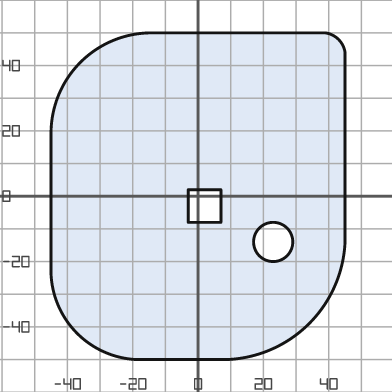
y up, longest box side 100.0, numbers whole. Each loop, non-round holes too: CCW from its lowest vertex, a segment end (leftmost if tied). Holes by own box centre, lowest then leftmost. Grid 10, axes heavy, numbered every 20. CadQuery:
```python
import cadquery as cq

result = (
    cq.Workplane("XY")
    .moveTo(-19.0, -50.0)
    .lineTo(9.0, -50.0)
    .threePointArc((34.0, -39.0), (45.0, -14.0))
    .lineTo(45.0, 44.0)
    .threePointArc((43.0, 48.0), (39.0, 50.0))
    .lineTo(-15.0, 50.0)
    .threePointArc((-36.0, 41.0), (-45.0, 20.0))
    .lineTo(-45.0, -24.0)
    .threePointArc((-37.0, -42.0), (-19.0, -50.0))
    .close()
    .moveTo(23.0, -14.0)
    .circle(6.0)
    .moveTo(-3.0, -8.0)
    .lineTo(7.0, -8.0)
    .lineTo(7.0, 2.0)
    .lineTo(-3.0, 2.0)
    .close()
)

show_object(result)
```